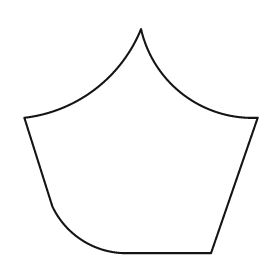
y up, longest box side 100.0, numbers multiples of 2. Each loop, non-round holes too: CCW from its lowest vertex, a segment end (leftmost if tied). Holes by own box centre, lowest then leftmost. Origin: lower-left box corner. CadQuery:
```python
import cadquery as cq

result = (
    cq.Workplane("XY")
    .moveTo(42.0, 0.0)
    .lineTo(80.0, 0.0)
    .lineTo(100.0, 58.0)
    .threePointArc((68.0, 68.0), (50.0, 96.0))
    .threePointArc((30.0, 70.0), (0.0, 58.0))
    .lineTo(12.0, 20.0)
    .threePointArc((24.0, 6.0), (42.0, 0.0))
    .close()
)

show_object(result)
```